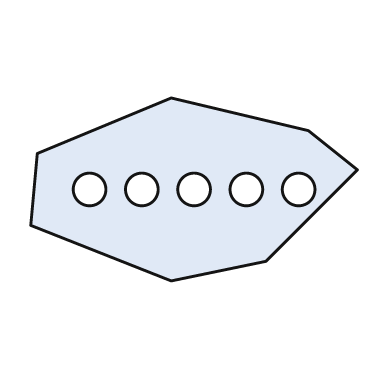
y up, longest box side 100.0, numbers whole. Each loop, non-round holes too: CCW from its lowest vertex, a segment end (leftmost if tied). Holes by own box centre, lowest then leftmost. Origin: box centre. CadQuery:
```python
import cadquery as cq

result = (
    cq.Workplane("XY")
    .moveTo(-7.0, -28.0)
    .lineTo(22.0, -22.0)
    .lineTo(50.0, 6.0)
    .lineTo(35.0, 18.0)
    .lineTo(-7.0, 28.0)
    .lineTo(-48.0, 11.0)
    .lineTo(-50.0, -11.0)
    .close()
    .moveTo(-32.0, 0.0)
    .circle(5.0)
    .moveTo(-16.0, 0.0)
    .circle(5.0)
    .moveTo(0.0, 0.0)
    .circle(5.0)
    .moveTo(16.0, 0.0)
    .circle(5.0)
    .moveTo(32.0, 0.0)
    .circle(5.0)
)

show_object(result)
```